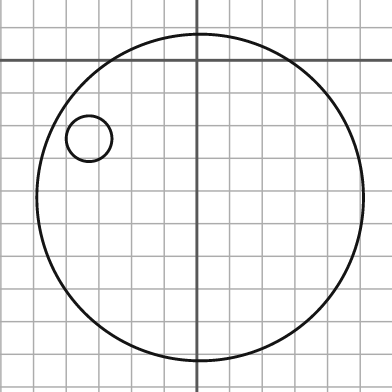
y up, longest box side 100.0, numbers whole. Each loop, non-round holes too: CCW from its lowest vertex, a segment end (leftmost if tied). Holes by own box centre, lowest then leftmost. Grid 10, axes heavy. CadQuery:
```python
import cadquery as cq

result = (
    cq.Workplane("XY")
    .moveTo(1.0, -42.0)
    .circle(50.0)
    .moveTo(-33.0, -24.0)
    .circle(7.0)
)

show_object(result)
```